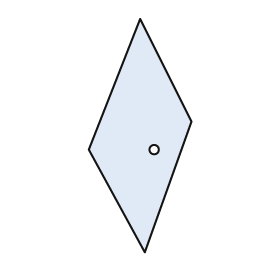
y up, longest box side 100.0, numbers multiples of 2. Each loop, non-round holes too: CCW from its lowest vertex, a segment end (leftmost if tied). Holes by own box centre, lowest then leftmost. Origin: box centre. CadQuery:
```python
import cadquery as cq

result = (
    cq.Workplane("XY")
    .moveTo(2.0, -50.0)
    .lineTo(22.0, 6.0)
    .lineTo(0.0, 50.0)
    .lineTo(-22.0, -6.0)
    .close()
    .moveTo(6.0, -6.0)
    .circle(2.0)
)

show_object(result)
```